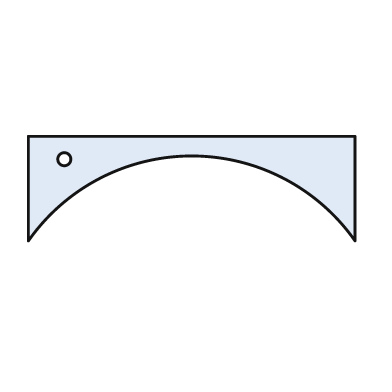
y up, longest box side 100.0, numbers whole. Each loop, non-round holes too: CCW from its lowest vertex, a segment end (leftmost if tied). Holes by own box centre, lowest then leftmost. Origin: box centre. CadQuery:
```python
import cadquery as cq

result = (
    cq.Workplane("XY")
    .moveTo(-50.0, -16.0)
    .threePointArc((0.0, 10.0), (50.0, -16.0))
    .lineTo(50.0, 16.0)
    .lineTo(-50.0, 16.0)
    .close()
    .moveTo(-39.0, 9.0)
    .circle(2.0)
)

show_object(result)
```